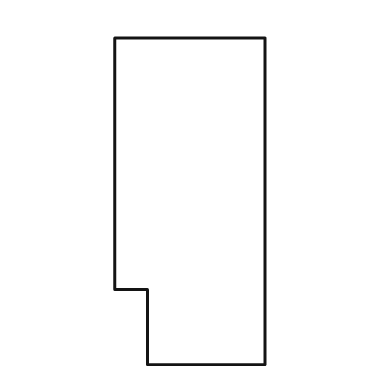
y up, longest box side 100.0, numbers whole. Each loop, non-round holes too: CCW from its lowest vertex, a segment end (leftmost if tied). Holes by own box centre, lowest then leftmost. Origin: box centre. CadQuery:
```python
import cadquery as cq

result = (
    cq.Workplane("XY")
    .moveTo(-13.0, -50.0)
    .lineTo(23.0, -50.0)
    .lineTo(23.0, 50.0)
    .lineTo(-23.0, 50.0)
    .lineTo(-23.0, -27.0)
    .lineTo(-13.0, -27.0)
    .close()
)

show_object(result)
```